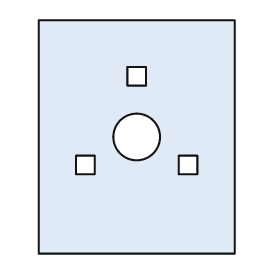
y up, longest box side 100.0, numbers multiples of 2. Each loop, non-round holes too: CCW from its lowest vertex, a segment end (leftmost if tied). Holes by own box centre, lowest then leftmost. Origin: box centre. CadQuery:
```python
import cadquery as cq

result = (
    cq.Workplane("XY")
    .moveTo(-42.0, -50.0)
    .lineTo(42.0, -50.0)
    .lineTo(42.0, 50.0)
    .lineTo(-42.0, 50.0)
    .close()
    .moveTo(-26.0, -16.0)
    .lineTo(-18.0, -16.0)
    .lineTo(-18.0, -8.0)
    .lineTo(-26.0, -8.0)
    .close()
    .moveTo(18.0, -16.0)
    .lineTo(26.0, -16.0)
    .lineTo(26.0, -8.0)
    .lineTo(18.0, -8.0)
    .close()
    .moveTo(0.0, 0.0)
    .circle(10.0)
    .moveTo(-4.0, 22.0)
    .lineTo(4.0, 22.0)
    .lineTo(4.0, 30.0)
    .lineTo(-4.0, 30.0)
    .close()
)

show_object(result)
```